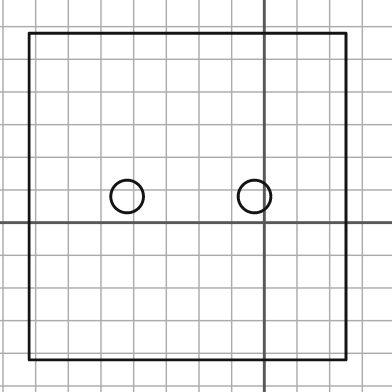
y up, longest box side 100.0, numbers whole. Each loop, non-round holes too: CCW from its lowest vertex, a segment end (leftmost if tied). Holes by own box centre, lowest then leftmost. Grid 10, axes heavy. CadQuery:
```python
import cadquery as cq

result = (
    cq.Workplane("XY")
    .moveTo(-72.0, -42.0)
    .lineTo(25.0, -42.0)
    .lineTo(25.0, 58.0)
    .lineTo(-72.0, 58.0)
    .close()
    .moveTo(-42.0, 8.0)
    .circle(5.0)
    .moveTo(-3.0, 8.0)
    .circle(5.0)
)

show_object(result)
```